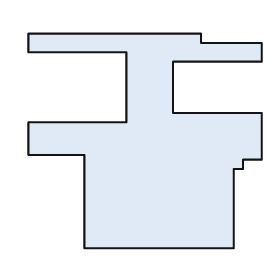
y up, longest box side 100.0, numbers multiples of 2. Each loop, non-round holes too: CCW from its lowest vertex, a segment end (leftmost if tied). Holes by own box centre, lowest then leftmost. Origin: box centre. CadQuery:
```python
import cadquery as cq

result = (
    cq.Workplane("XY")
    .moveTo(-26.0, -46.0)
    .lineTo(38.0, -46.0)
    .lineTo(38.0, -12.0)
    .lineTo(42.0, -12.0)
    .lineTo(42.0, -8.0)
    .lineTo(50.0, -8.0)
    .lineTo(50.0, 12.0)
    .lineTo(12.0, 12.0)
    .lineTo(12.0, 34.0)
    .lineTo(50.0, 34.0)
    .lineTo(50.0, 42.0)
    .lineTo(24.0, 42.0)
    .lineTo(24.0, 46.0)
    .lineTo(-50.0, 46.0)
    .lineTo(-50.0, 38.0)
    .lineTo(-8.0, 38.0)
    .lineTo(-8.0, 8.0)
    .lineTo(-50.0, 8.0)
    .lineTo(-50.0, -6.0)
    .lineTo(-26.0, -6.0)
    .close()
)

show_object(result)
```